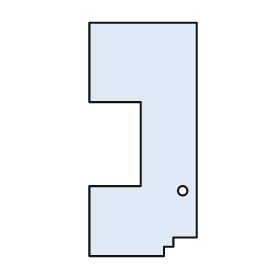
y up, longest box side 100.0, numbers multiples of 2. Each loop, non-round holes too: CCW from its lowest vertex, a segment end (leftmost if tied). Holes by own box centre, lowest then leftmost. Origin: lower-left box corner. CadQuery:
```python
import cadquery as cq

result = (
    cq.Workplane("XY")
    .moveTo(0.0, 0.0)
    .lineTo(32.0, 0.0)
    .lineTo(32.0, 4.0)
    .lineTo(36.0, 4.0)
    .lineTo(36.0, 8.0)
    .lineTo(46.0, 8.0)
    .lineTo(46.0, 100.0)
    .lineTo(0.0, 100.0)
    .lineTo(0.0, 66.0)
    .lineTo(22.0, 66.0)
    .lineTo(22.0, 30.0)
    .lineTo(0.0, 30.0)
    .close()
    .moveTo(40.0, 28.0)
    .circle(2.0)
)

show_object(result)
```